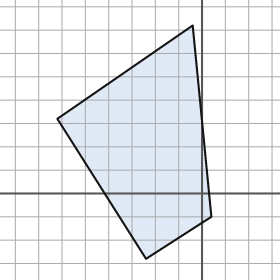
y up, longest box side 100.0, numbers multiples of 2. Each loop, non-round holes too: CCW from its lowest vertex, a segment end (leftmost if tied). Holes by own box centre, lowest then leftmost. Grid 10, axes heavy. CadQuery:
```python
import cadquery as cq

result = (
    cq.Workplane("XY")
    .moveTo(-24.0, -28.0)
    .lineTo(4.0, -10.0)
    .lineTo(-4.0, 72.0)
    .lineTo(-62.0, 32.0)
    .close()
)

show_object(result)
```